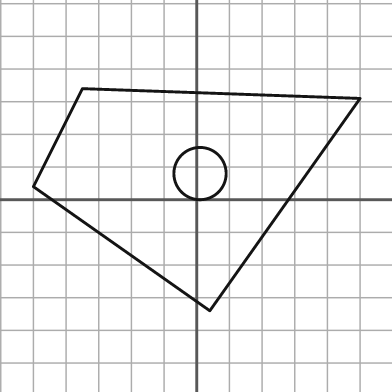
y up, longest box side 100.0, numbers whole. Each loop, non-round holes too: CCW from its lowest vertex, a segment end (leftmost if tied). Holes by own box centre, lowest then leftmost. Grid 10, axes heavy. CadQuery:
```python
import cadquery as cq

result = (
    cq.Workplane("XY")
    .moveTo(4.0, -34.0)
    .lineTo(50.0, 31.0)
    .lineTo(-35.0, 34.0)
    .lineTo(-50.0, 4.0)
    .close()
    .moveTo(1.0, 8.0)
    .circle(8.0)
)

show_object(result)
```